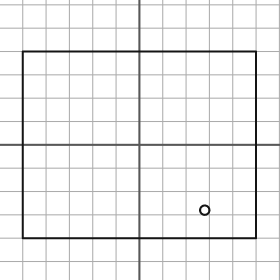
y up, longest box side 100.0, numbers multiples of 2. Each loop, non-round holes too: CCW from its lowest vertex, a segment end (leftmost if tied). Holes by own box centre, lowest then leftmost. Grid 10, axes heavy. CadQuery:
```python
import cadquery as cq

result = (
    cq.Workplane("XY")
    .moveTo(-50.0, -40.0)
    .lineTo(50.0, -40.0)
    .lineTo(50.0, 40.0)
    .lineTo(-50.0, 40.0)
    .close()
    .moveTo(28.0, -28.0)
    .circle(2.0)
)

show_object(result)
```